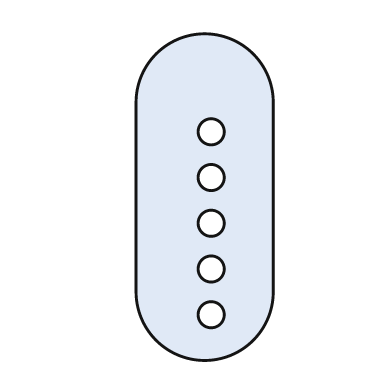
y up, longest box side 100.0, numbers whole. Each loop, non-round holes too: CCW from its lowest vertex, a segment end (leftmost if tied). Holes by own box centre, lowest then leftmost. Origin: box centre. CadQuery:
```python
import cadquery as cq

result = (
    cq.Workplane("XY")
    .moveTo(-21.0, -29.0)
    .threePointArc((0.0, -50.0), (21.0, -29.0))
    .lineTo(21.0, 29.0)
    .threePointArc((0.0, 50.0), (-21.0, 29.0))
    .close()
    .moveTo(2.0, -36.0)
    .circle(4.0)
    .moveTo(2.0, -22.0)
    .circle(4.0)
    .moveTo(2.0, -8.0)
    .circle(4.0)
    .moveTo(2.0, 6.0)
    .circle(4.0)
    .moveTo(2.0, 20.0)
    .circle(4.0)
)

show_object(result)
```